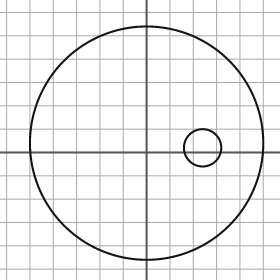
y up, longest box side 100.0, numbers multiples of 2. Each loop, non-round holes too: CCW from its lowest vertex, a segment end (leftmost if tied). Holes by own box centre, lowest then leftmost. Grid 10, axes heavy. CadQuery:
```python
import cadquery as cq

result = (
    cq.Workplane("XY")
    .moveTo(0.0, 4.0)
    .circle(50.0)
    .moveTo(24.0, 2.0)
    .circle(8.0)
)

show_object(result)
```